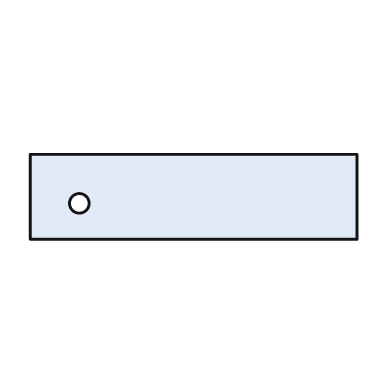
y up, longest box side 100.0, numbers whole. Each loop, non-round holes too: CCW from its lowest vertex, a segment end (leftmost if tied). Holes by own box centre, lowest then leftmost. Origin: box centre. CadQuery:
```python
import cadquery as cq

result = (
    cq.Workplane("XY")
    .moveTo(-50.0, -13.0)
    .lineTo(50.0, -13.0)
    .lineTo(50.0, 13.0)
    .lineTo(-50.0, 13.0)
    .close()
    .moveTo(-35.0, -2.0)
    .circle(3.0)
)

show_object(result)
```